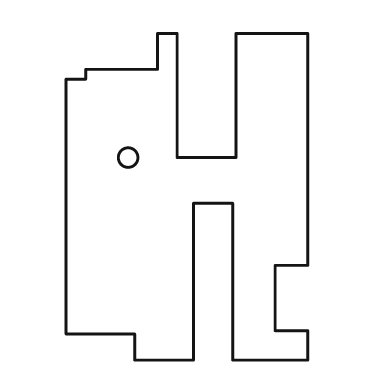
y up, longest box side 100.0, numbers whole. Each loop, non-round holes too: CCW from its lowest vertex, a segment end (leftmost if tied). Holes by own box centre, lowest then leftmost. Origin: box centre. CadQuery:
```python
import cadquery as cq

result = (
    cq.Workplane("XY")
    .moveTo(-16.0, -50.0)
    .lineTo(2.0, -50.0)
    .lineTo(2.0, -2.0)
    .lineTo(14.0, -2.0)
    .lineTo(14.0, -50.0)
    .lineTo(37.0, -50.0)
    .lineTo(37.0, -41.0)
    .lineTo(27.0, -41.0)
    .lineTo(27.0, -21.0)
    .lineTo(37.0, -21.0)
    .lineTo(37.0, 50.0)
    .lineTo(15.0, 50.0)
    .lineTo(15.0, 12.0)
    .lineTo(-3.0, 12.0)
    .lineTo(-3.0, 50.0)
    .lineTo(-9.0, 50.0)
    .lineTo(-9.0, 39.0)
    .lineTo(-31.0, 39.0)
    .lineTo(-31.0, 36.0)
    .lineTo(-37.0, 36.0)
    .lineTo(-37.0, -42.0)
    .lineTo(-16.0, -42.0)
    .close()
    .moveTo(-18.0, 12.0)
    .circle(3.0)
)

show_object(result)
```